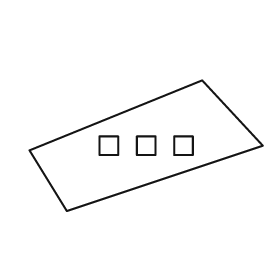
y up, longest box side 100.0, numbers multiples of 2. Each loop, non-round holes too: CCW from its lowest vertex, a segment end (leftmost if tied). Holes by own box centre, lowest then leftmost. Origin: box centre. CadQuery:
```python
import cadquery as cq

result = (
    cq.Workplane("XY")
    .moveTo(-34.0, -28.0)
    .lineTo(50.0, 0.0)
    .lineTo(24.0, 28.0)
    .lineTo(-50.0, -2.0)
    .close()
    .moveTo(-20.0, -4.0)
    .lineTo(-12.0, -4.0)
    .lineTo(-12.0, 4.0)
    .lineTo(-20.0, 4.0)
    .close()
    .moveTo(-4.0, -4.0)
    .lineTo(4.0, -4.0)
    .lineTo(4.0, 4.0)
    .lineTo(-4.0, 4.0)
    .close()
    .moveTo(12.0, -4.0)
    .lineTo(20.0, -4.0)
    .lineTo(20.0, 4.0)
    .lineTo(12.0, 4.0)
    .close()
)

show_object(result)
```